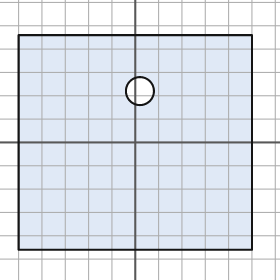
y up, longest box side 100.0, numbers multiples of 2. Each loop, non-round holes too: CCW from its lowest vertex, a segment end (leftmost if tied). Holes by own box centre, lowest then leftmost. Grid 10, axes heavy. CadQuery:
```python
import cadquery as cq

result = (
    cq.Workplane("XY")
    .moveTo(-50.0, -46.0)
    .lineTo(50.0, -46.0)
    .lineTo(50.0, 46.0)
    .lineTo(-50.0, 46.0)
    .close()
    .moveTo(2.0, 22.0)
    .circle(6.0)
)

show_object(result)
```